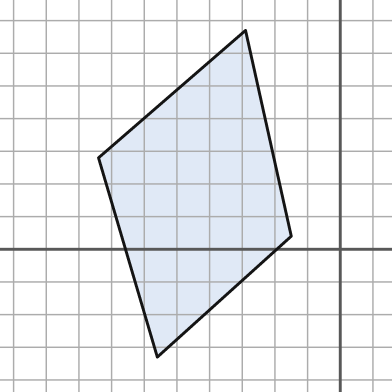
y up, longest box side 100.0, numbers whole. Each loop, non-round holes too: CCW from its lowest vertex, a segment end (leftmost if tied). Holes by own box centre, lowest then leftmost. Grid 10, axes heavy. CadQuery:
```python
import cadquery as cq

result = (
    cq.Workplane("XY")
    .moveTo(-56.0, -33.0)
    .lineTo(-15.0, 4.0)
    .lineTo(-29.0, 67.0)
    .lineTo(-74.0, 28.0)
    .close()
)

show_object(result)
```